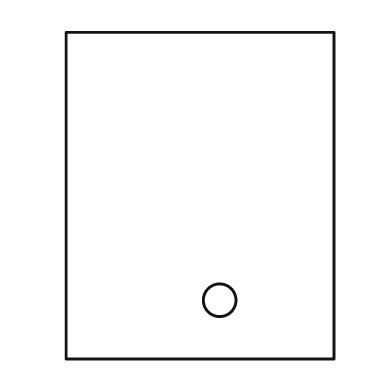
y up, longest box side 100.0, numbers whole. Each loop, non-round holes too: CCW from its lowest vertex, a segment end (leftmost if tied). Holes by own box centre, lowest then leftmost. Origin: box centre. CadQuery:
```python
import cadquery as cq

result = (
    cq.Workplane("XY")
    .moveTo(-41.0, -50.0)
    .lineTo(41.0, -50.0)
    .lineTo(41.0, 50.0)
    .lineTo(-41.0, 50.0)
    .close()
    .moveTo(6.0, -32.0)
    .circle(5.0)
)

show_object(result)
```